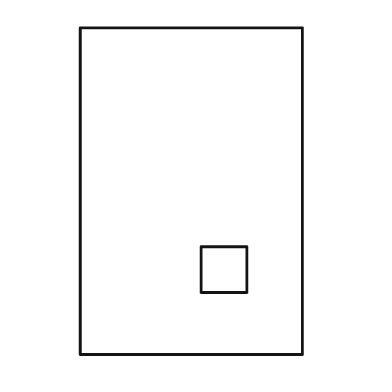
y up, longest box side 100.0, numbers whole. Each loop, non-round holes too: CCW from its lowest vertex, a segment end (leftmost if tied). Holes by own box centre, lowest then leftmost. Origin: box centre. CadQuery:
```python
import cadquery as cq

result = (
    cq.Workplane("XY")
    .moveTo(-34.0, -50.0)
    .lineTo(34.0, -50.0)
    .lineTo(34.0, 50.0)
    .lineTo(-34.0, 50.0)
    .close()
    .moveTo(3.0, -31.0)
    .lineTo(17.0, -31.0)
    .lineTo(17.0, -17.0)
    .lineTo(3.0, -17.0)
    .close()
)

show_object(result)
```